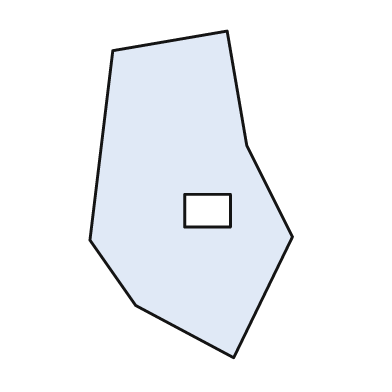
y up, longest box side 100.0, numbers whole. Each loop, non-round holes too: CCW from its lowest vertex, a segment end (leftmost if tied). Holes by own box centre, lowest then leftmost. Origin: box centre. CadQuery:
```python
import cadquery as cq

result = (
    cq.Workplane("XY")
    .moveTo(13.0, -50.0)
    .lineTo(31.0, -13.0)
    .lineTo(17.0, 15.0)
    .lineTo(11.0, 50.0)
    .lineTo(-24.0, 44.0)
    .lineTo(-31.0, -14.0)
    .lineTo(-17.0, -34.0)
    .close()
    .moveTo(-2.0, -10.0)
    .lineTo(12.0, -10.0)
    .lineTo(12.0, 0.0)
    .lineTo(-2.0, 0.0)
    .close()
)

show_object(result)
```